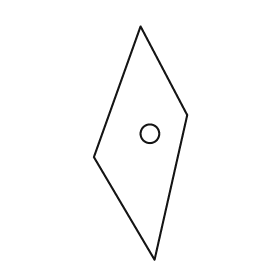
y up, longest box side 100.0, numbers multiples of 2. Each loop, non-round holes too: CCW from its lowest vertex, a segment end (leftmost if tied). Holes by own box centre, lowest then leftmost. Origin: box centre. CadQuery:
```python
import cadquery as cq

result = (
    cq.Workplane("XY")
    .moveTo(6.0, -50.0)
    .lineTo(20.0, 12.0)
    .lineTo(0.0, 50.0)
    .lineTo(-20.0, -6.0)
    .close()
    .moveTo(4.0, 4.0)
    .circle(4.0)
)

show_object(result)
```